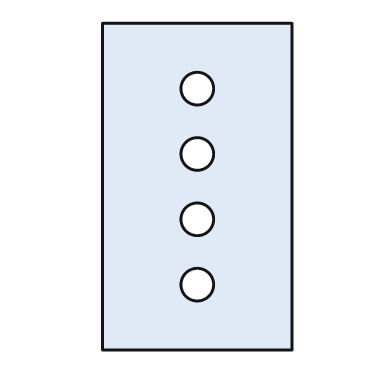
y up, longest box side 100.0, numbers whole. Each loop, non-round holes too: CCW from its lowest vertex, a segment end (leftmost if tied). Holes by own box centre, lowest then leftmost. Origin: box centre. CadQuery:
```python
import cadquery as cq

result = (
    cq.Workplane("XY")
    .moveTo(-29.0, -50.0)
    .lineTo(29.0, -50.0)
    .lineTo(29.0, 50.0)
    .lineTo(-29.0, 50.0)
    .close()
    .moveTo(0.0, -30.0)
    .circle(5.0)
    .moveTo(0.0, -10.0)
    .circle(5.0)
    .moveTo(0.0, 10.0)
    .circle(5.0)
    .moveTo(0.0, 30.0)
    .circle(5.0)
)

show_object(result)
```